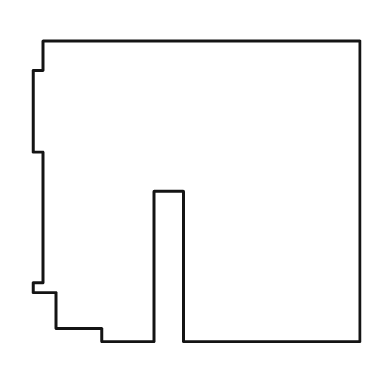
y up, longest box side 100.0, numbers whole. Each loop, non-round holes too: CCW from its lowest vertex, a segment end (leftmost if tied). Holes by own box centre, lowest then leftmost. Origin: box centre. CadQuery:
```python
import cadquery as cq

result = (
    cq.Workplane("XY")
    .moveTo(-29.0, -46.0)
    .lineTo(-13.0, -46.0)
    .lineTo(-13.0, 0.0)
    .lineTo(-4.0, 0.0)
    .lineTo(-4.0, -46.0)
    .lineTo(50.0, -46.0)
    .lineTo(50.0, 46.0)
    .lineTo(-47.0, 46.0)
    .lineTo(-47.0, 37.0)
    .lineTo(-50.0, 37.0)
    .lineTo(-50.0, 12.0)
    .lineTo(-47.0, 12.0)
    .lineTo(-47.0, -28.0)
    .lineTo(-50.0, -28.0)
    .lineTo(-50.0, -31.0)
    .lineTo(-43.0, -31.0)
    .lineTo(-43.0, -42.0)
    .lineTo(-29.0, -42.0)
    .close()
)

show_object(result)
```